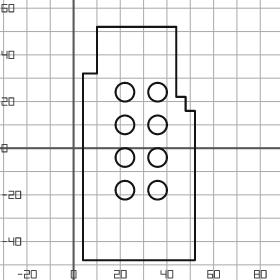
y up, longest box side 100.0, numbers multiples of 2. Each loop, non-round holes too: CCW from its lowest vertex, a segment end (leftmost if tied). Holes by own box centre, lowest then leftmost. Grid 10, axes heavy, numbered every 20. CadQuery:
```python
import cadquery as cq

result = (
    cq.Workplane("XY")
    .moveTo(4.0, -48.0)
    .lineTo(52.0, -48.0)
    .lineTo(52.0, 16.0)
    .lineTo(48.0, 16.0)
    .lineTo(48.0, 22.0)
    .lineTo(44.0, 22.0)
    .lineTo(44.0, 52.0)
    .lineTo(10.0, 52.0)
    .lineTo(10.0, 32.0)
    .lineTo(4.0, 32.0)
    .close()
    .moveTo(22.0, -18.0)
    .circle(4.0)
    .moveTo(36.0, -18.0)
    .circle(4.0)
    .moveTo(22.0, -4.0)
    .circle(4.0)
    .moveTo(36.0, -4.0)
    .circle(4.0)
    .moveTo(22.0, 10.0)
    .circle(4.0)
    .moveTo(36.0, 10.0)
    .circle(4.0)
    .moveTo(22.0, 24.0)
    .circle(4.0)
    .moveTo(36.0, 24.0)
    .circle(4.0)
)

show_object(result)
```